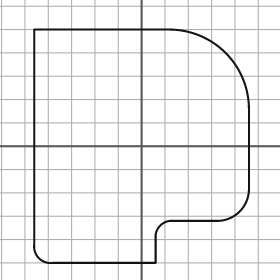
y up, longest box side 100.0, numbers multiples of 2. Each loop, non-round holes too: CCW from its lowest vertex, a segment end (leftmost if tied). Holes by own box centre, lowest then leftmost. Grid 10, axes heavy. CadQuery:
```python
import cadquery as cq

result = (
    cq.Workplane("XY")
    .moveTo(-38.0, -50.0)
    .lineTo(6.0, -50.0)
    .lineTo(6.0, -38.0)
    .threePointArc((8.0, -34.0), (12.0, -32.0))
    .lineTo(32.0, -32.0)
    .threePointArc((42.0, -28.0), (46.0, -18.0))
    .lineTo(46.0, 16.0)
    .threePointArc((36.0, 40.0), (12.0, 50.0))
    .lineTo(-46.0, 50.0)
    .lineTo(-46.0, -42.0)
    .threePointArc((-44.0, -48.0), (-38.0, -50.0))
    .close()
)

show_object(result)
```